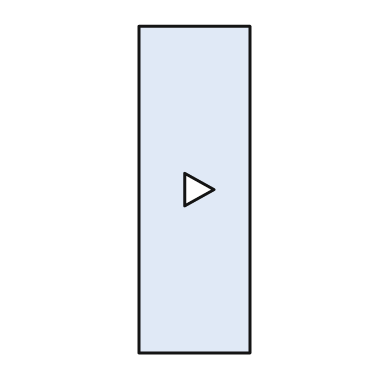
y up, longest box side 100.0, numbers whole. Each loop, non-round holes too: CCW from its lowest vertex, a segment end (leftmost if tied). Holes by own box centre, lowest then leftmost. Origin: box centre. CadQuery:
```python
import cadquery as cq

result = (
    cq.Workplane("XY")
    .moveTo(-17.0, -50.0)
    .lineTo(17.0, -50.0)
    .lineTo(17.0, 50.0)
    .lineTo(-17.0, 50.0)
    .close()
    .moveTo(-3.0, -5.0)
    .lineTo(6.0, 0.0)
    .lineTo(-3.0, 5.0)
    .close()
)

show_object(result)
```